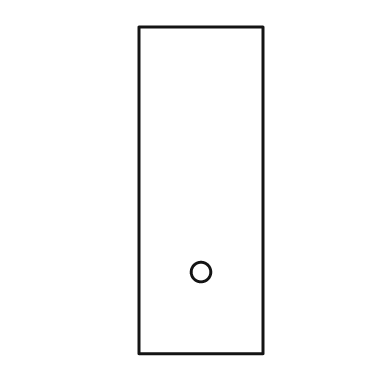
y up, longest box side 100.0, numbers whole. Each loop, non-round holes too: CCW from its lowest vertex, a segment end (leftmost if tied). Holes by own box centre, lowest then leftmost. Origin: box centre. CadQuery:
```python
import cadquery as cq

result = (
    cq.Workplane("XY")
    .moveTo(-19.0, -50.0)
    .lineTo(19.0, -50.0)
    .lineTo(19.0, 50.0)
    .lineTo(-19.0, 50.0)
    .close()
    .moveTo(0.0, -25.0)
    .circle(3.0)
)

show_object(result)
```